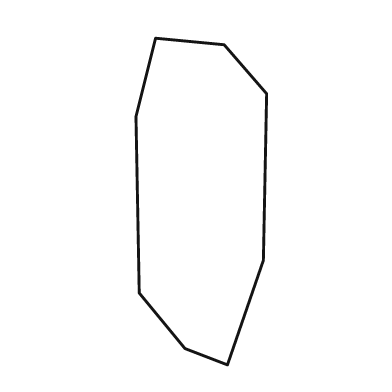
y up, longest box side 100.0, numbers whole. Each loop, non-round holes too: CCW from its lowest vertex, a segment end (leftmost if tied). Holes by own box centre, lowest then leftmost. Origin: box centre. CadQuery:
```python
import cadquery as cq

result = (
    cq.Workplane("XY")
    .moveTo(8.0, -50.0)
    .lineTo(19.0, -18.0)
    .lineTo(20.0, 33.0)
    .lineTo(7.0, 48.0)
    .lineTo(-14.0, 50.0)
    .lineTo(-20.0, 26.0)
    .lineTo(-19.0, -28.0)
    .lineTo(-5.0, -45.0)
    .close()
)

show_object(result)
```